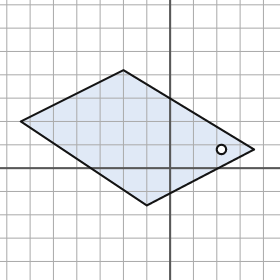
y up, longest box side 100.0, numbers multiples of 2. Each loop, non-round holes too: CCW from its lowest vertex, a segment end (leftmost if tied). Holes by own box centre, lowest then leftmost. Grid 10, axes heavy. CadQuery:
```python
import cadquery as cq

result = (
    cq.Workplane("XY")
    .moveTo(-10.0, -16.0)
    .lineTo(36.0, 8.0)
    .lineTo(-20.0, 42.0)
    .lineTo(-64.0, 20.0)
    .close()
    .moveTo(22.0, 8.0)
    .circle(2.0)
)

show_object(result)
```